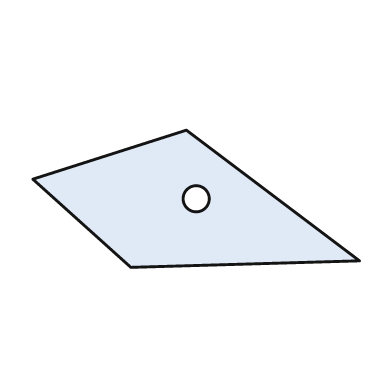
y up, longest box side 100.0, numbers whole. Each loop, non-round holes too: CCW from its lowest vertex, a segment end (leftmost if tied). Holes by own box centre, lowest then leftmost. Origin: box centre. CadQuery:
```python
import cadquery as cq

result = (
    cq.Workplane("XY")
    .moveTo(-20.0, -21.0)
    .lineTo(50.0, -19.0)
    .lineTo(-3.0, 21.0)
    .lineTo(-50.0, 6.0)
    .close()
    .moveTo(0.0, 0.0)
    .circle(4.0)
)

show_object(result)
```